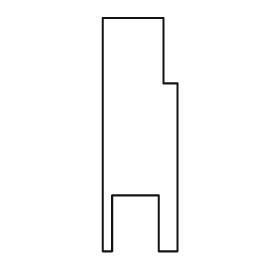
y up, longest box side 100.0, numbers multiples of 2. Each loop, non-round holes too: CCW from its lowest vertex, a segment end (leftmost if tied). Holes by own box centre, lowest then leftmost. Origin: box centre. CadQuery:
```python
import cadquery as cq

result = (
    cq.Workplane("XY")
    .moveTo(-16.0, -50.0)
    .lineTo(-12.0, -50.0)
    .lineTo(-12.0, -26.0)
    .lineTo(8.0, -26.0)
    .lineTo(8.0, -50.0)
    .lineTo(16.0, -50.0)
    .lineTo(16.0, 22.0)
    .lineTo(10.0, 22.0)
    .lineTo(10.0, 50.0)
    .lineTo(-16.0, 50.0)
    .close()
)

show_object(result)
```